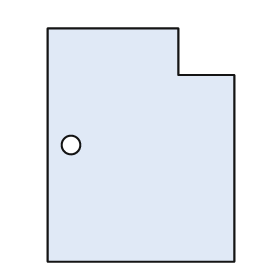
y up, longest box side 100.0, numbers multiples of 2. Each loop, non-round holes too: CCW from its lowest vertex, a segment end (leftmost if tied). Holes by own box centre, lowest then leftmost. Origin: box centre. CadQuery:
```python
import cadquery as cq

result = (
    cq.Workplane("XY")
    .moveTo(-40.0, -50.0)
    .lineTo(40.0, -50.0)
    .lineTo(40.0, 30.0)
    .lineTo(16.0, 30.0)
    .lineTo(16.0, 50.0)
    .lineTo(-40.0, 50.0)
    .close()
    .moveTo(-30.0, 0.0)
    .circle(4.0)
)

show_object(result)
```